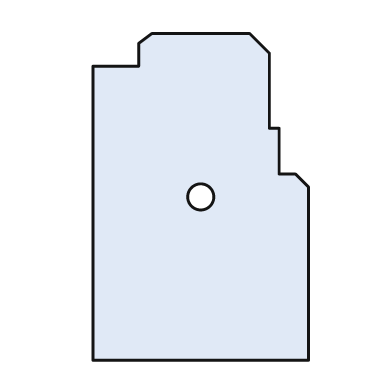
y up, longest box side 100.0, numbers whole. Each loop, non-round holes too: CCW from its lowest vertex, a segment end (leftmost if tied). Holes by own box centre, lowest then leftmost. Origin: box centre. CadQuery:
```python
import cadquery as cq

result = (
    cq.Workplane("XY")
    .moveTo(-33.0, -50.0)
    .lineTo(33.0, -50.0)
    .lineTo(33.0, 3.0)
    .lineTo(29.0, 7.0)
    .lineTo(24.0, 7.0)
    .lineTo(24.0, 21.0)
    .lineTo(21.0, 21.0)
    .lineTo(21.0, 44.0)
    .lineTo(15.0, 50.0)
    .lineTo(-15.0, 50.0)
    .lineTo(-19.0, 47.0)
    .lineTo(-19.0, 40.0)
    .lineTo(-33.0, 40.0)
    .close()
    .moveTo(0.0, 0.0)
    .circle(4.0)
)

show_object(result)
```